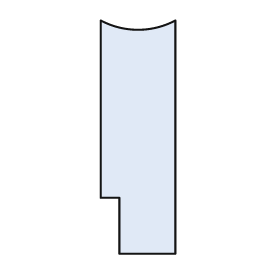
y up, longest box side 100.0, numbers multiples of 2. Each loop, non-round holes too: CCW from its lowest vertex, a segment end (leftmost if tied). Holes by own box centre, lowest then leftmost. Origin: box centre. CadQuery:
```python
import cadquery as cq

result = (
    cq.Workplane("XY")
    .moveTo(-8.0, -50.0)
    .lineTo(16.0, -50.0)
    .lineTo(16.0, 50.0)
    .threePointArc((0.0, 46.0), (-16.0, 50.0))
    .lineTo(-16.0, -26.0)
    .lineTo(-8.0, -26.0)
    .close()
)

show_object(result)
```